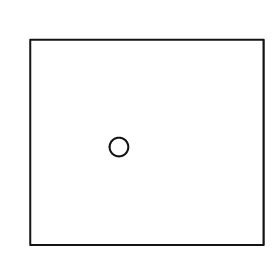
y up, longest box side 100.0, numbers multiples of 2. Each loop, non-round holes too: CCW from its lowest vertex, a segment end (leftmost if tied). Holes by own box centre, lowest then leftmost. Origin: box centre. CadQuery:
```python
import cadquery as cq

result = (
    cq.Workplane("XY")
    .moveTo(-50.0, -44.0)
    .lineTo(50.0, -44.0)
    .lineTo(50.0, 44.0)
    .lineTo(-50.0, 44.0)
    .close()
    .moveTo(-12.0, -2.0)
    .circle(4.0)
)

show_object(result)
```